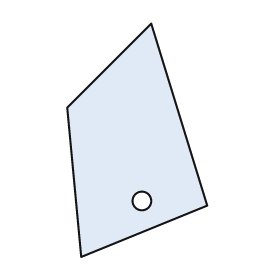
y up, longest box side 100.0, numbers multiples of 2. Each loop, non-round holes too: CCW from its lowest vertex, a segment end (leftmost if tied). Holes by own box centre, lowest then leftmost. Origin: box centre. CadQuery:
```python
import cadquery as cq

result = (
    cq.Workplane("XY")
    .moveTo(-24.0, -50.0)
    .lineTo(30.0, -28.0)
    .lineTo(6.0, 50.0)
    .lineTo(-30.0, 14.0)
    .close()
    .moveTo(2.0, -26.0)
    .circle(4.0)
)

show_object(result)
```